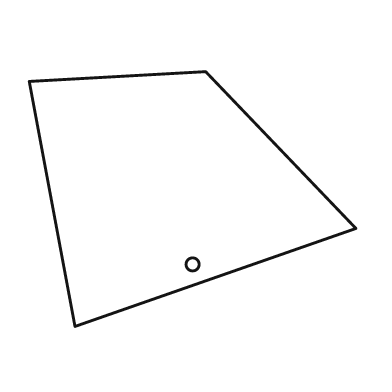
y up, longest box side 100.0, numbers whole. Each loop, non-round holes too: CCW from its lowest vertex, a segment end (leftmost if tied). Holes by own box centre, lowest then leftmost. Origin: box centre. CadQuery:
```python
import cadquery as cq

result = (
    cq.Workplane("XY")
    .moveTo(-36.0, -39.0)
    .lineTo(50.0, -9.0)
    .lineTo(4.0, 39.0)
    .lineTo(-50.0, 36.0)
    .close()
    .moveTo(0.0, -20.0)
    .circle(2.0)
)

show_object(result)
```